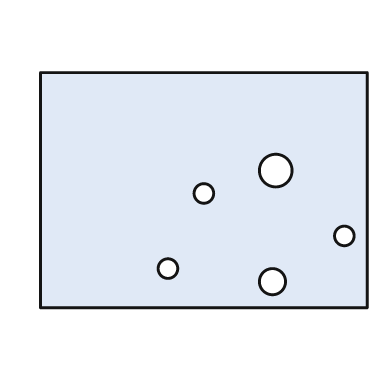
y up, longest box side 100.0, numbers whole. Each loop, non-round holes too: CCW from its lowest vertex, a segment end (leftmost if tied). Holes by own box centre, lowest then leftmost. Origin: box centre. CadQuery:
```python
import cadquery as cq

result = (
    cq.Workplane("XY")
    .moveTo(-50.0, -36.0)
    .lineTo(50.0, -36.0)
    .lineTo(50.0, 36.0)
    .lineTo(-50.0, 36.0)
    .close()
    .moveTo(21.0, -28.0)
    .circle(4.0)
    .moveTo(-11.0, -24.0)
    .circle(3.0)
    .moveTo(43.0, -14.0)
    .circle(3.0)
    .moveTo(0.0, -1.0)
    .circle(3.0)
    .moveTo(22.0, 6.0)
    .circle(5.0)
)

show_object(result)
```